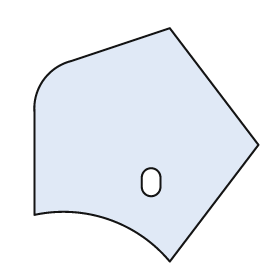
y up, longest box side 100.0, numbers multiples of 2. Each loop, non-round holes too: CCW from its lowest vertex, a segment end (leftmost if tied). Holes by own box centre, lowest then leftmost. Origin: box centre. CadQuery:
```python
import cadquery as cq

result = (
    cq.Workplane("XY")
    .moveTo(10.0, -50.0)
    .lineTo(48.0, 0.0)
    .lineTo(10.0, 50.0)
    .lineTo(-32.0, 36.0)
    .threePointArc((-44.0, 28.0), (-48.0, 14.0))
    .lineTo(-48.0, -30.0)
    .threePointArc((-16.0, -32.0), (10.0, -50.0))
    .close()
    .moveTo(-2.0, -18.0)
    .threePointArc((2.0, -22.0), (6.0, -18.0))
    .lineTo(6.0, -14.0)
    .threePointArc((2.0, -10.0), (-2.0, -14.0))
    .close()
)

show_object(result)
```